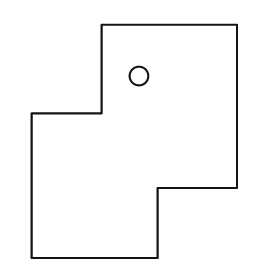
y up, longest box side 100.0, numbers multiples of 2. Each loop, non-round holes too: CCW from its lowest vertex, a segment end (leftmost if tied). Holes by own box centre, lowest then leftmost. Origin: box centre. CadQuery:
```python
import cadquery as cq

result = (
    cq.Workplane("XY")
    .moveTo(-44.0, -50.0)
    .lineTo(10.0, -50.0)
    .lineTo(10.0, -20.0)
    .lineTo(44.0, -20.0)
    .lineTo(44.0, 50.0)
    .lineTo(-14.0, 50.0)
    .lineTo(-14.0, 12.0)
    .lineTo(-44.0, 12.0)
    .close()
    .moveTo(2.0, 28.0)
    .circle(4.0)
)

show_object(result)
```